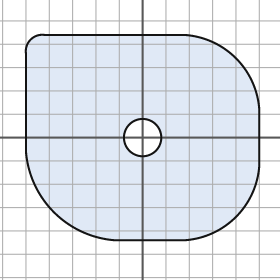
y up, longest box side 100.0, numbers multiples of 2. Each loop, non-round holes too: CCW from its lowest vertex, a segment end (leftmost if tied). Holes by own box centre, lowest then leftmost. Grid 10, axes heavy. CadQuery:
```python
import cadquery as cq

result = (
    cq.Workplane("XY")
    .moveTo(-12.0, -44.0)
    .lineTo(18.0, -44.0)
    .threePointArc((40.0, -34.0), (50.0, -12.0))
    .lineTo(50.0, 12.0)
    .threePointArc((40.0, 34.0), (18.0, 44.0))
    .lineTo(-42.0, 44.0)
    .threePointArc((-48.0, 42.0), (-50.0, 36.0))
    .lineTo(-50.0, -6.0)
    .threePointArc((-38.0, -32.0), (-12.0, -44.0))
    .close()
    .moveTo(0.0, 0.0)
    .circle(8.0)
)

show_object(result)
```